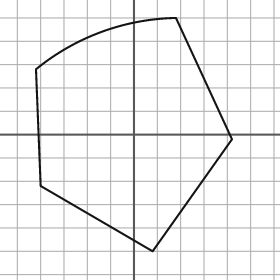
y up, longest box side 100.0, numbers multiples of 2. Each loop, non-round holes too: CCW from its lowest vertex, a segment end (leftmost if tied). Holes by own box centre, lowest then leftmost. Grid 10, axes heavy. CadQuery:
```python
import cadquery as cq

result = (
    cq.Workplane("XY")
    .moveTo(8.0, -50.0)
    .lineTo(42.0, -2.0)
    .lineTo(18.0, 50.0)
    .threePointArc((-14.0, 44.0), (-42.0, 28.0))
    .lineTo(-40.0, -22.0)
    .close()
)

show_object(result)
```